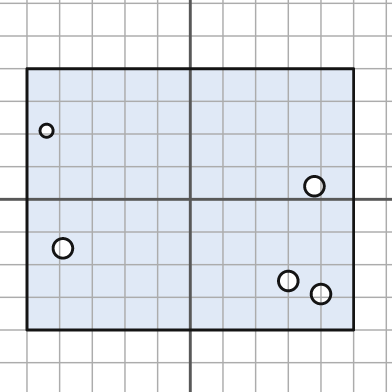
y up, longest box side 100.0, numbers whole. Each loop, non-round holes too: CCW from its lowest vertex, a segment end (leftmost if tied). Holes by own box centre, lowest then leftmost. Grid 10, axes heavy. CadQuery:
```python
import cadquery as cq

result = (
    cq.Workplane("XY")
    .moveTo(-50.0, -40.0)
    .lineTo(50.0, -40.0)
    .lineTo(50.0, 40.0)
    .lineTo(-50.0, 40.0)
    .close()
    .moveTo(40.0, -29.0)
    .circle(3.0)
    .moveTo(30.0, -25.0)
    .circle(3.0)
    .moveTo(-39.0, -15.0)
    .circle(3.0)
    .moveTo(38.0, 4.0)
    .circle(3.0)
    .moveTo(-44.0, 21.0)
    .circle(2.0)
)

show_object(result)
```